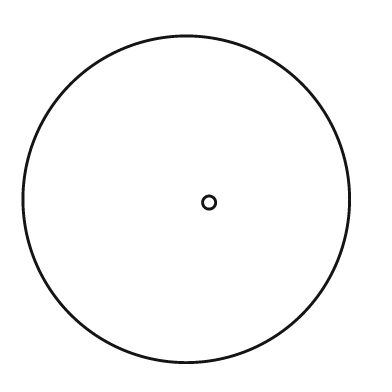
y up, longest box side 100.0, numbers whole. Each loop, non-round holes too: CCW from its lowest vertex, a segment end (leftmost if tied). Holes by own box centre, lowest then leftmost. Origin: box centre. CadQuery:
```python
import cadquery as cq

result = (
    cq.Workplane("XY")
    .moveTo(0.0, 0.0)
    .circle(50.0)
    .moveTo(7.0, -1.0)
    .circle(2.0)
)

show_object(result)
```